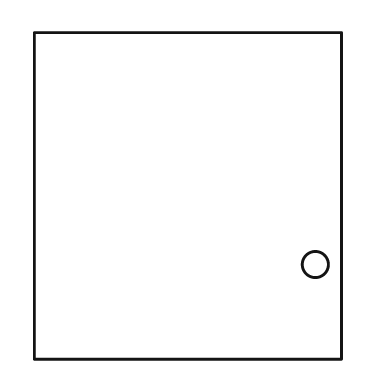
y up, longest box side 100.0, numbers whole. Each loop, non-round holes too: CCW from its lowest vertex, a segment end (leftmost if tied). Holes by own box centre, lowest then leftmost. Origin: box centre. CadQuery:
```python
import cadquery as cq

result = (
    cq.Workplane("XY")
    .moveTo(-47.0, -50.0)
    .lineTo(47.0, -50.0)
    .lineTo(47.0, 50.0)
    .lineTo(-47.0, 50.0)
    .close()
    .moveTo(39.0, -21.0)
    .circle(4.0)
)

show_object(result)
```